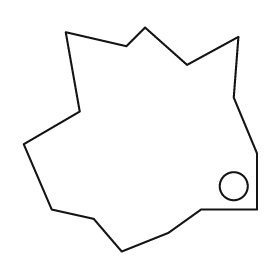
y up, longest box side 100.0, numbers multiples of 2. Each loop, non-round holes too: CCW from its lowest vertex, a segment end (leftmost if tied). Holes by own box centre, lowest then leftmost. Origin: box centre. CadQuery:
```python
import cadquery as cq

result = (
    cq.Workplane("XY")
    .moveTo(-8.0, -48.0)
    .lineTo(12.0, -40.0)
    .lineTo(26.0, -30.0)
    .lineTo(50.0, -30.0)
    .lineTo(50.0, -6.0)
    .lineTo(40.0, 18.0)
    .lineTo(42.0, 44.0)
    .lineTo(20.0, 32.0)
    .lineTo(2.0, 48.0)
    .lineTo(-6.0, 40.0)
    .lineTo(-32.0, 46.0)
    .lineTo(-26.0, 12.0)
    .lineTo(-50.0, -2.0)
    .lineTo(-38.0, -30.0)
    .lineTo(-20.0, -34.0)
    .close()
    .moveTo(40.0, -20.0)
    .circle(6.0)
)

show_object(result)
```